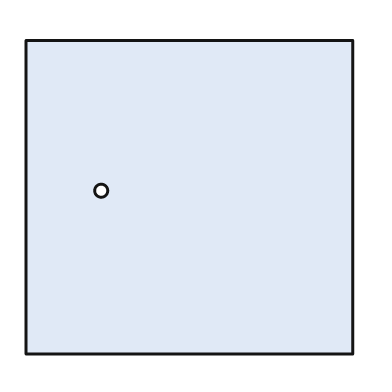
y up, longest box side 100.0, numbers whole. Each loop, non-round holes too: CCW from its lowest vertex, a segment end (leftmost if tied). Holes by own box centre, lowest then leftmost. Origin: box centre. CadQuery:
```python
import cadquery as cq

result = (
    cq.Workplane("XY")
    .moveTo(-50.0, -48.0)
    .lineTo(50.0, -48.0)
    .lineTo(50.0, 48.0)
    .lineTo(-50.0, 48.0)
    .close()
    .moveTo(-27.0, 2.0)
    .circle(2.0)
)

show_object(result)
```